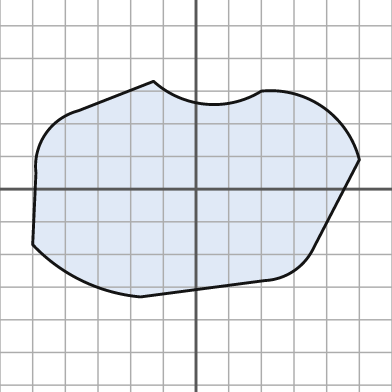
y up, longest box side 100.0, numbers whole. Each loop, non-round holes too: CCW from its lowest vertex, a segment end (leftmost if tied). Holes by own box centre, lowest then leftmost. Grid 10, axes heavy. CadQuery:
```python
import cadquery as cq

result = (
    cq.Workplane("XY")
    .moveTo(-17.0, -33.0)
    .lineTo(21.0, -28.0)
    .threePointArc((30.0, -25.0), (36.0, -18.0))
    .lineTo(50.0, 9.0)
    .threePointArc((39.0, 25.0), (20.0, 30.0))
    .threePointArc((3.0, 26.0), (-13.0, 33.0))
    .lineTo(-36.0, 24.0)
    .threePointArc((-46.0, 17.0), (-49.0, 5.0))
    .lineTo(-50.0, -17.0)
    .threePointArc((-35.0, -28.0), (-17.0, -33.0))
    .close()
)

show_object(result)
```